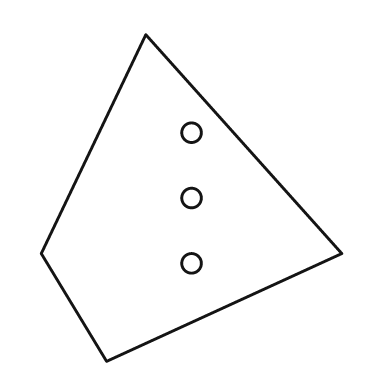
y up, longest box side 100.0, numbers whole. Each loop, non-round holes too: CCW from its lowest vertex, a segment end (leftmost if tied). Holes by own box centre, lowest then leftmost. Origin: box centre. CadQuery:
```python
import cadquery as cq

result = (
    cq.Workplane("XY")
    .moveTo(-26.0, -50.0)
    .lineTo(46.0, -17.0)
    .lineTo(-14.0, 50.0)
    .lineTo(-46.0, -17.0)
    .close()
    .moveTo(0.0, -20.0)
    .circle(3.0)
    .moveTo(0.0, 0.0)
    .circle(3.0)
    .moveTo(0.0, 20.0)
    .circle(3.0)
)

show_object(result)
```